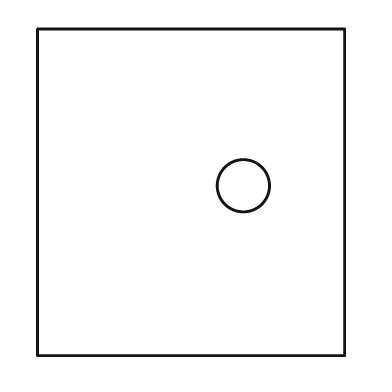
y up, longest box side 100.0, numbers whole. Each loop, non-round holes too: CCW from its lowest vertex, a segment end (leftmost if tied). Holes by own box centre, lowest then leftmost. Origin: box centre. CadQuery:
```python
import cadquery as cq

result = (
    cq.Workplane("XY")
    .moveTo(-47.0, -50.0)
    .lineTo(47.0, -50.0)
    .lineTo(47.0, 50.0)
    .lineTo(-47.0, 50.0)
    .close()
    .moveTo(16.0, 2.0)
    .circle(8.0)
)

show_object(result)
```